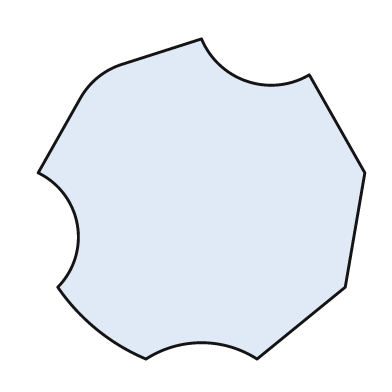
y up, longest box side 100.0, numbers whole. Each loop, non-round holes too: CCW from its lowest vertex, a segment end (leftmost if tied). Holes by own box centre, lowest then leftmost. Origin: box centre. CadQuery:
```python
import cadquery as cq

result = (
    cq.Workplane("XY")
    .moveTo(-17.0, -49.0)
    .threePointArc((0.0, -44.0), (17.0, -49.0))
    .lineTo(44.0, -27.0)
    .lineTo(50.0, 8.0)
    .lineTo(33.0, 38.0)
    .threePointArc((14.0, 36.0), (0.0, 49.0))
    .lineTo(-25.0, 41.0)
    .threePointArc((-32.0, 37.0), (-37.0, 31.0))
    .lineTo(-50.0, 8.0)
    .threePointArc((-38.0, -8.0), (-44.0, -27.0))
    .threePointArc((-32.0, -40.0), (-17.0, -49.0))
    .close()
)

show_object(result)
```